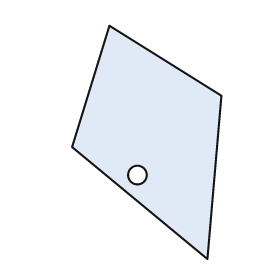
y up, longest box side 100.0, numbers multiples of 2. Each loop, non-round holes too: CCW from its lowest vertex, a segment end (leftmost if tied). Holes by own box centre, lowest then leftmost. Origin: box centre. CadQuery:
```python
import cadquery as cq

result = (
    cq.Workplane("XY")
    .moveTo(26.0, -50.0)
    .lineTo(32.0, 20.0)
    .lineTo(-16.0, 50.0)
    .lineTo(-32.0, -2.0)
    .close()
    .moveTo(-4.0, -14.0)
    .circle(4.0)
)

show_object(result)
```